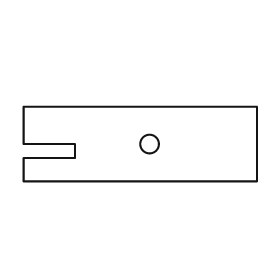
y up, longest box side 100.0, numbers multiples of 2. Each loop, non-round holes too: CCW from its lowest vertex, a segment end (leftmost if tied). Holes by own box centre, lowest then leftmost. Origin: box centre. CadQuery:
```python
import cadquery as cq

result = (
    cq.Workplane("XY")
    .moveTo(-50.0, -16.0)
    .lineTo(50.0, -16.0)
    .lineTo(50.0, 16.0)
    .lineTo(-50.0, 16.0)
    .lineTo(-50.0, 0.0)
    .lineTo(-28.0, 0.0)
    .lineTo(-28.0, -6.0)
    .lineTo(-50.0, -6.0)
    .close()
    .moveTo(4.0, 0.0)
    .circle(4.0)
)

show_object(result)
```